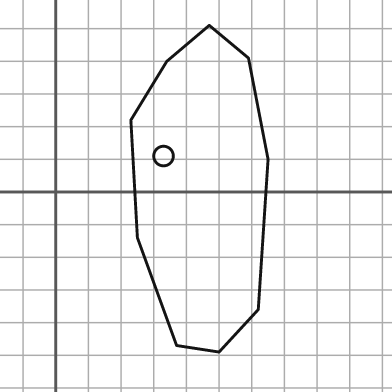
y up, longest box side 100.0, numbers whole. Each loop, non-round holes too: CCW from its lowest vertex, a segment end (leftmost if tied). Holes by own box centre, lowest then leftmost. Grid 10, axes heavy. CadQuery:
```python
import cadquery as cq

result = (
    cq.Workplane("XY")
    .moveTo(50.0, -49.0)
    .lineTo(62.0, -36.0)
    .lineTo(65.0, 10.0)
    .lineTo(59.0, 41.0)
    .lineTo(47.0, 51.0)
    .lineTo(34.0, 40.0)
    .lineTo(23.0, 22.0)
    .lineTo(25.0, -14.0)
    .lineTo(37.0, -47.0)
    .close()
    .moveTo(33.0, 11.0)
    .circle(3.0)
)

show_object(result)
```